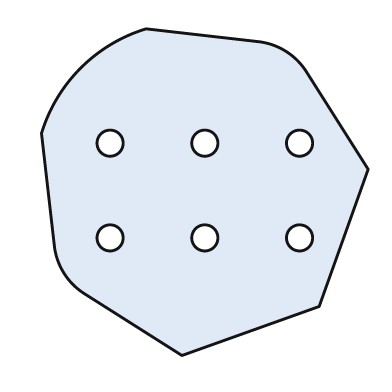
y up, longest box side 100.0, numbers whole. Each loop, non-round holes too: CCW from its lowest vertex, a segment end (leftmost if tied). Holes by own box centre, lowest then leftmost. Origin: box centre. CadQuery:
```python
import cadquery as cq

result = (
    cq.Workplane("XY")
    .moveTo(-7.0, -50.0)
    .lineTo(35.0, -35.0)
    .lineTo(50.0, 7.0)
    .lineTo(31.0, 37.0)
    .threePointArc((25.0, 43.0), (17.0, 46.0))
    .lineTo(-18.0, 50.0)
    .threePointArc((-38.0, 38.0), (-50.0, 18.0))
    .lineTo(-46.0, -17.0)
    .threePointArc((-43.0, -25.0), (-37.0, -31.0))
    .close()
    .moveTo(-29.0, -14.0)
    .circle(4.0)
    .moveTo(0.0, -14.0)
    .circle(4.0)
    .moveTo(29.0, -14.0)
    .circle(4.0)
    .moveTo(-29.0, 15.0)
    .circle(4.0)
    .moveTo(0.0, 15.0)
    .circle(4.0)
    .moveTo(29.0, 15.0)
    .circle(4.0)
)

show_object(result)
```